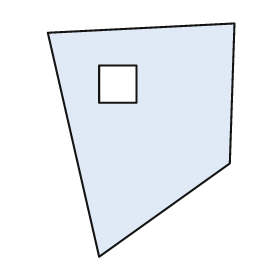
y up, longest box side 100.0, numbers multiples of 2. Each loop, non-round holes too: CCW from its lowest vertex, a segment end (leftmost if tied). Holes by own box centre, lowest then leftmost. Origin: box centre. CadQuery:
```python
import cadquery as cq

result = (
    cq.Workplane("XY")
    .moveTo(-18.0, -50.0)
    .lineTo(38.0, -10.0)
    .lineTo(40.0, 50.0)
    .lineTo(-40.0, 46.0)
    .close()
    .moveTo(-18.0, 16.0)
    .lineTo(-2.0, 16.0)
    .lineTo(-2.0, 32.0)
    .lineTo(-18.0, 32.0)
    .close()
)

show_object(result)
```